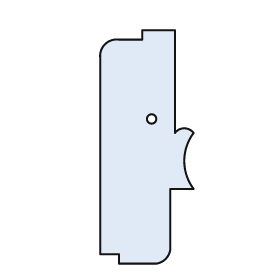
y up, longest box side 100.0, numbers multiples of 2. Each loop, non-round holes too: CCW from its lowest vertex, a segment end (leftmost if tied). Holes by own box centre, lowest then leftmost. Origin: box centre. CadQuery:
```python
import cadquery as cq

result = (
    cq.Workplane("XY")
    .moveTo(-12.0, -50.0)
    .lineTo(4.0, -50.0)
    .threePointArc((8.0, -48.0), (10.0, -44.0))
    .lineTo(10.0, -18.0)
    .lineTo(20.0, -18.0)
    .threePointArc((16.0, -6.0), (20.0, 6.0))
    .threePointArc((16.0, 8.0), (12.0, 6.0))
    .lineTo(12.0, 50.0)
    .lineTo(-2.0, 50.0)
    .lineTo(-2.0, 46.0)
    .lineTo(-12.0, 46.0)
    .threePointArc((-18.0, 44.0), (-20.0, 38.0))
    .lineTo(-20.0, -46.0)
    .lineTo(-12.0, -46.0)
    .close()
    .moveTo(2.0, 12.0)
    .circle(2.0)
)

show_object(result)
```